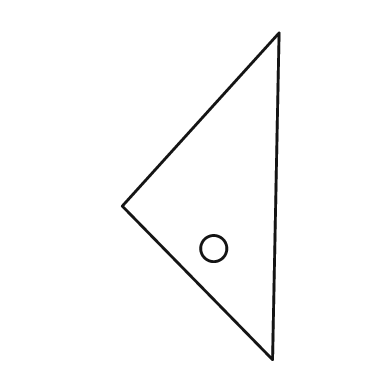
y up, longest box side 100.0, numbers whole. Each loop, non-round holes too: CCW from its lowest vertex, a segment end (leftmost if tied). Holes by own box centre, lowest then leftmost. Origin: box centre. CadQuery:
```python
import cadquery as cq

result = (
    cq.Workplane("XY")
    .moveTo(22.0, -50.0)
    .lineTo(24.0, 50.0)
    .lineTo(-24.0, -3.0)
    .close()
    .moveTo(4.0, -16.0)
    .circle(4.0)
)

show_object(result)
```